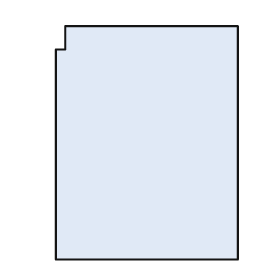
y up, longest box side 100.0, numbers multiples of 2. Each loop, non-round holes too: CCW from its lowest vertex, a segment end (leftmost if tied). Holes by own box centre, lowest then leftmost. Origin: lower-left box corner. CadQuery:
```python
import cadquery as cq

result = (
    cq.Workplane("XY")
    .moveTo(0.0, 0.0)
    .lineTo(78.0, 0.0)
    .lineTo(78.0, 100.0)
    .lineTo(4.0, 100.0)
    .lineTo(4.0, 90.0)
    .lineTo(0.0, 90.0)
    .close()
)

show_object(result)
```